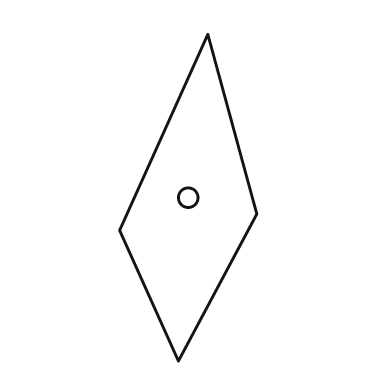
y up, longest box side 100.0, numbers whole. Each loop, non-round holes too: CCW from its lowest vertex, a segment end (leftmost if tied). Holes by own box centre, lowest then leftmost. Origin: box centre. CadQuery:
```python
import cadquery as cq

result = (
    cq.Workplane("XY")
    .moveTo(-3.0, -50.0)
    .lineTo(21.0, -5.0)
    .lineTo(6.0, 50.0)
    .lineTo(-21.0, -10.0)
    .close()
    .moveTo(0.0, 0.0)
    .circle(3.0)
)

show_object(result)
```